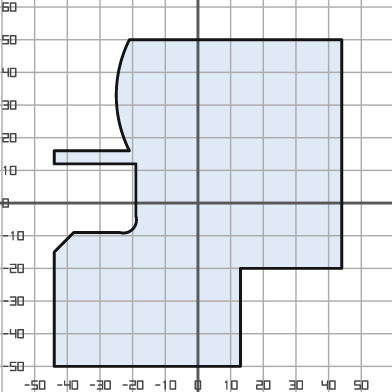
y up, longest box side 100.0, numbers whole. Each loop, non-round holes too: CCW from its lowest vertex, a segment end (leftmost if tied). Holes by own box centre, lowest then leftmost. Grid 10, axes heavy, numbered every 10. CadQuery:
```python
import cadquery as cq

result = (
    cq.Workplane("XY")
    .moveTo(-44.0, -50.0)
    .lineTo(13.0, -50.0)
    .lineTo(13.0, -20.0)
    .lineTo(44.0, -20.0)
    .lineTo(44.0, 50.0)
    .lineTo(-21.0, 50.0)
    .threePointArc((-25.0, 33.0), (-21.0, 16.0))
    .lineTo(-44.0, 16.0)
    .lineTo(-44.0, 12.0)
    .lineTo(-19.0, 12.0)
    .lineTo(-19.0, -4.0)
    .threePointArc((-20.0, -8.0), (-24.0, -9.0))
    .lineTo(-38.0, -9.0)
    .lineTo(-44.0, -15.0)
    .close()
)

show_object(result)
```